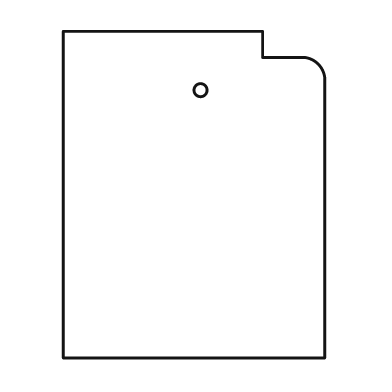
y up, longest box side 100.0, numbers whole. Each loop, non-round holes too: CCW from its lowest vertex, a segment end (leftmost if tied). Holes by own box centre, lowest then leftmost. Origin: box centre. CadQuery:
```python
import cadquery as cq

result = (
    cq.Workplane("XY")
    .moveTo(-40.0, -50.0)
    .lineTo(40.0, -50.0)
    .lineTo(40.0, 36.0)
    .threePointArc((38.0, 40.0), (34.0, 42.0))
    .lineTo(21.0, 42.0)
    .lineTo(21.0, 50.0)
    .lineTo(-40.0, 50.0)
    .close()
    .moveTo(2.0, 32.0)
    .circle(2.0)
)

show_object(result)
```